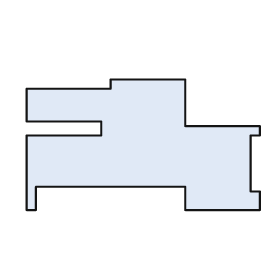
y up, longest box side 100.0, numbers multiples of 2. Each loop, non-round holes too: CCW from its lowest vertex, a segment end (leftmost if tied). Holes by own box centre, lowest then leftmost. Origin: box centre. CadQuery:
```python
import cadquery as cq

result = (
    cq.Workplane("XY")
    .moveTo(-50.0, -28.0)
    .lineTo(-46.0, -28.0)
    .lineTo(-46.0, -18.0)
    .lineTo(18.0, -18.0)
    .lineTo(18.0, -28.0)
    .lineTo(50.0, -28.0)
    .lineTo(50.0, -20.0)
    .lineTo(46.0, -20.0)
    .lineTo(46.0, 4.0)
    .lineTo(50.0, 4.0)
    .lineTo(50.0, 8.0)
    .lineTo(18.0, 8.0)
    .lineTo(18.0, 28.0)
    .lineTo(-14.0, 28.0)
    .lineTo(-14.0, 24.0)
    .lineTo(-50.0, 24.0)
    .lineTo(-50.0, 10.0)
    .lineTo(-18.0, 10.0)
    .lineTo(-18.0, 4.0)
    .lineTo(-50.0, 4.0)
    .close()
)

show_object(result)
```